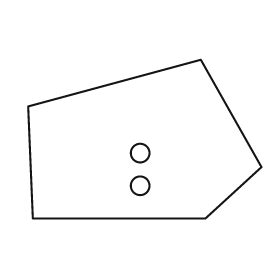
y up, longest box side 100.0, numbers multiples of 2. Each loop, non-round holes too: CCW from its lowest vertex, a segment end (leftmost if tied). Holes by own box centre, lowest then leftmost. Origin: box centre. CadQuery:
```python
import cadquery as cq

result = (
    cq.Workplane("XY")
    .moveTo(-48.0, -34.0)
    .lineTo(26.0, -34.0)
    .lineTo(50.0, -12.0)
    .lineTo(24.0, 34.0)
    .lineTo(-50.0, 14.0)
    .close()
    .moveTo(-2.0, -20.0)
    .circle(4.0)
    .moveTo(-2.0, -6.0)
    .circle(4.0)
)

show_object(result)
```